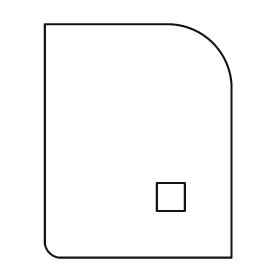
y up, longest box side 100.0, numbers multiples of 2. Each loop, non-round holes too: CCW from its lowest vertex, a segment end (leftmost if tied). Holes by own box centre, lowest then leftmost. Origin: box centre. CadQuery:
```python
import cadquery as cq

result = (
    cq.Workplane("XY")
    .moveTo(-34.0, -50.0)
    .lineTo(40.0, -50.0)
    .lineTo(40.0, 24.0)
    .threePointArc((32.0, 42.0), (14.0, 50.0))
    .lineTo(-40.0, 50.0)
    .lineTo(-40.0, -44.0)
    .threePointArc((-38.0, -48.0), (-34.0, -50.0))
    .close()
    .moveTo(8.0, -30.0)
    .lineTo(20.0, -30.0)
    .lineTo(20.0, -18.0)
    .lineTo(8.0, -18.0)
    .close()
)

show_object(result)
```